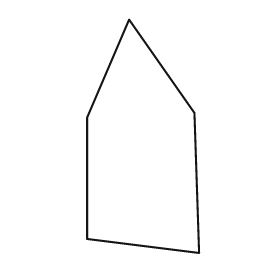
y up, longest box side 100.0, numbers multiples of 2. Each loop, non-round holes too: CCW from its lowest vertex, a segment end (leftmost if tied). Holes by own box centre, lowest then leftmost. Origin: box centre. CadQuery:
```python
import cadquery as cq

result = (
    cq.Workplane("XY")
    .moveTo(24.0, -50.0)
    .lineTo(22.0, 10.0)
    .lineTo(-6.0, 50.0)
    .lineTo(-24.0, 8.0)
    .lineTo(-24.0, -44.0)
    .close()
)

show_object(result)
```